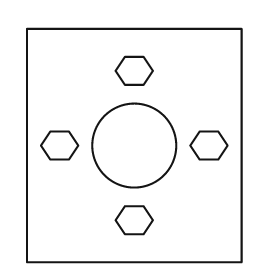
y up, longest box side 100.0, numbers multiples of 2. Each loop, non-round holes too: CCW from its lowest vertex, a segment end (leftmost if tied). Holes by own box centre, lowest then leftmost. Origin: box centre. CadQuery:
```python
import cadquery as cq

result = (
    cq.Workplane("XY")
    .moveTo(-46.0, -50.0)
    .lineTo(46.0, -50.0)
    .lineTo(46.0, 50.0)
    .lineTo(-46.0, 50.0)
    .close()
    .moveTo(-4.0, -38.0)
    .lineTo(4.0, -38.0)
    .lineTo(8.0, -32.0)
    .lineTo(4.0, -26.0)
    .lineTo(-4.0, -26.0)
    .lineTo(-8.0, -32.0)
    .close()
    .moveTo(-36.0, -6.0)
    .lineTo(-28.0, -6.0)
    .lineTo(-24.0, 0.0)
    .lineTo(-28.0, 6.0)
    .lineTo(-36.0, 6.0)
    .lineTo(-40.0, 0.0)
    .close()
    .moveTo(0.0, 0.0)
    .circle(18.0)
    .moveTo(28.0, -6.0)
    .lineTo(36.0, -6.0)
    .lineTo(40.0, 0.0)
    .lineTo(36.0, 6.0)
    .lineTo(28.0, 6.0)
    .lineTo(24.0, 0.0)
    .close()
    .moveTo(-4.0, 26.0)
    .lineTo(4.0, 26.0)
    .lineTo(8.0, 32.0)
    .lineTo(4.0, 38.0)
    .lineTo(-4.0, 38.0)
    .lineTo(-8.0, 32.0)
    .close()
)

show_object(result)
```